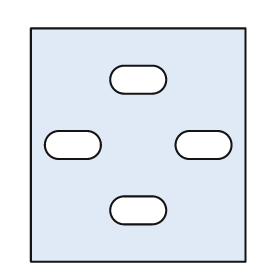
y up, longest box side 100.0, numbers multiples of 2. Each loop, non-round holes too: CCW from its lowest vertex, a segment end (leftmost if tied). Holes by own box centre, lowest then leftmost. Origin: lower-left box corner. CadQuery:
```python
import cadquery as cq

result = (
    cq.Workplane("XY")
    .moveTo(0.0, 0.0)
    .lineTo(92.0, 0.0)
    .lineTo(92.0, 100.0)
    .lineTo(0.0, 100.0)
    .close()
    .moveTo(40.0, 16.0)
    .lineTo(52.0, 16.0)
    .threePointArc((58.0, 22.0), (52.0, 28.0))
    .lineTo(40.0, 28.0)
    .threePointArc((34.0, 22.0), (40.0, 16.0))
    .close()
    .moveTo(12.0, 44.0)
    .lineTo(24.0, 44.0)
    .threePointArc((30.0, 50.0), (24.0, 56.0))
    .lineTo(12.0, 56.0)
    .threePointArc((6.0, 50.0), (12.0, 44.0))
    .close()
    .moveTo(68.0, 44.0)
    .lineTo(80.0, 44.0)
    .threePointArc((86.0, 50.0), (80.0, 56.0))
    .lineTo(68.0, 56.0)
    .threePointArc((62.0, 50.0), (68.0, 44.0))
    .close()
    .moveTo(40.0, 72.0)
    .lineTo(52.0, 72.0)
    .threePointArc((58.0, 78.0), (52.0, 84.0))
    .lineTo(40.0, 84.0)
    .threePointArc((34.0, 78.0), (40.0, 72.0))
    .close()
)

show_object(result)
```